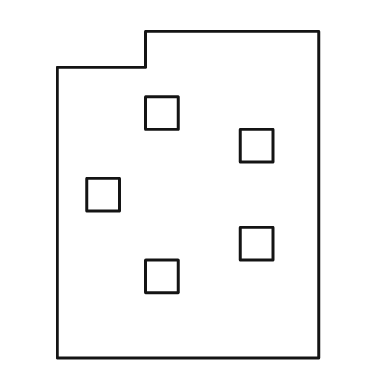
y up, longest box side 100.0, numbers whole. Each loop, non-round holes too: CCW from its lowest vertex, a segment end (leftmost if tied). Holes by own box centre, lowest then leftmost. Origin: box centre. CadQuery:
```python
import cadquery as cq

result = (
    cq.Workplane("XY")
    .moveTo(-40.0, -50.0)
    .lineTo(40.0, -50.0)
    .lineTo(40.0, 50.0)
    .lineTo(-13.0, 50.0)
    .lineTo(-13.0, 39.0)
    .lineTo(-40.0, 39.0)
    .close()
    .moveTo(-13.0, -30.0)
    .lineTo(-3.0, -30.0)
    .lineTo(-3.0, -20.0)
    .lineTo(-13.0, -20.0)
    .close()
    .moveTo(16.0, -20.0)
    .lineTo(26.0, -20.0)
    .lineTo(26.0, -10.0)
    .lineTo(16.0, -10.0)
    .close()
    .moveTo(-31.0, -5.0)
    .lineTo(-21.0, -5.0)
    .lineTo(-21.0, 5.0)
    .lineTo(-31.0, 5.0)
    .close()
    .moveTo(16.0, 10.0)
    .lineTo(26.0, 10.0)
    .lineTo(26.0, 20.0)
    .lineTo(16.0, 20.0)
    .close()
    .moveTo(-13.0, 20.0)
    .lineTo(-3.0, 20.0)
    .lineTo(-3.0, 30.0)
    .lineTo(-13.0, 30.0)
    .close()
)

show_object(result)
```